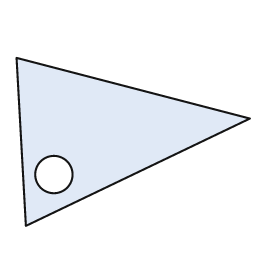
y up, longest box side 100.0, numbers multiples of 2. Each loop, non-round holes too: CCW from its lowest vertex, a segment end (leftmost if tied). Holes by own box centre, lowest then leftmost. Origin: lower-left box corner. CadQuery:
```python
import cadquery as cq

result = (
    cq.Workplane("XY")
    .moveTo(4.0, 0.0)
    .lineTo(100.0, 46.0)
    .lineTo(0.0, 72.0)
    .close()
    .moveTo(16.0, 22.0)
    .circle(8.0)
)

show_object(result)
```